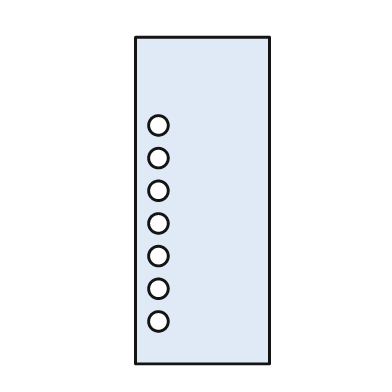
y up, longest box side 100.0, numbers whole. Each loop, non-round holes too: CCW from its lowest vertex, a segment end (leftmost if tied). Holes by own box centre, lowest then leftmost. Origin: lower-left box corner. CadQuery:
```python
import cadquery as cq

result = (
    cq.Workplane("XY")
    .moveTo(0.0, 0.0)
    .lineTo(41.0, 0.0)
    .lineTo(41.0, 100.0)
    .lineTo(0.0, 100.0)
    .close()
    .moveTo(7.0, 13.0)
    .circle(3.0)
    .moveTo(7.0, 23.0)
    .circle(3.0)
    .moveTo(7.0, 33.0)
    .circle(3.0)
    .moveTo(7.0, 43.0)
    .circle(3.0)
    .moveTo(7.0, 53.0)
    .circle(3.0)
    .moveTo(7.0, 63.0)
    .circle(3.0)
    .moveTo(7.0, 73.0)
    .circle(3.0)
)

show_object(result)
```